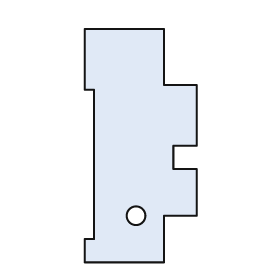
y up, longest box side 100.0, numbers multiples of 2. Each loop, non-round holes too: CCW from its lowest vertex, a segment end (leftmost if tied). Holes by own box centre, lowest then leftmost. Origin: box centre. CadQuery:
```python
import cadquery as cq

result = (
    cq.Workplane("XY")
    .moveTo(-24.0, -50.0)
    .lineTo(10.0, -50.0)
    .lineTo(10.0, -30.0)
    .lineTo(24.0, -30.0)
    .lineTo(24.0, -10.0)
    .lineTo(14.0, -10.0)
    .lineTo(14.0, 0.0)
    .lineTo(24.0, 0.0)
    .lineTo(24.0, 26.0)
    .lineTo(10.0, 26.0)
    .lineTo(10.0, 50.0)
    .lineTo(-24.0, 50.0)
    .lineTo(-24.0, 24.0)
    .lineTo(-20.0, 24.0)
    .lineTo(-20.0, -40.0)
    .lineTo(-24.0, -40.0)
    .close()
    .moveTo(-2.0, -30.0)
    .circle(4.0)
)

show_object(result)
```